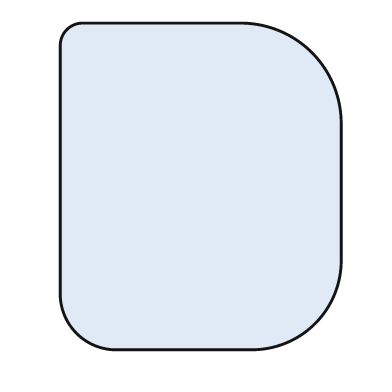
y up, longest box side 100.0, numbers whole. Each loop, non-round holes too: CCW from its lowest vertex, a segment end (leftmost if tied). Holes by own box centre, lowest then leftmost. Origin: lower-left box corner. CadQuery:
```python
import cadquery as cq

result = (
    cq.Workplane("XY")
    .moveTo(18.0, 0.0)
    .lineTo(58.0, 0.0)
    .threePointArc((78.0, 8.0), (86.0, 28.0))
    .lineTo(86.0, 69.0)
    .threePointArc((77.0, 91.0), (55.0, 100.0))
    .lineTo(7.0, 100.0)
    .threePointArc((2.0, 98.0), (0.0, 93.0))
    .lineTo(0.0, 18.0)
    .threePointArc((5.0, 5.0), (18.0, 0.0))
    .close()
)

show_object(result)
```